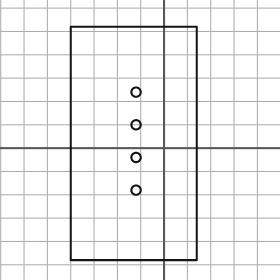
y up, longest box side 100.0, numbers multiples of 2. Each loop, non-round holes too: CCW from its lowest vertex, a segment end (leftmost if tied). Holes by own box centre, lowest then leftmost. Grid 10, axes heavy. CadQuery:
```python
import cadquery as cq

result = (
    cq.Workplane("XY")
    .moveTo(-40.0, -48.0)
    .lineTo(14.0, -48.0)
    .lineTo(14.0, 52.0)
    .lineTo(-40.0, 52.0)
    .close()
    .moveTo(-12.0, -18.0)
    .circle(2.0)
    .moveTo(-12.0, -4.0)
    .circle(2.0)
    .moveTo(-12.0, 10.0)
    .circle(2.0)
    .moveTo(-12.0, 24.0)
    .circle(2.0)
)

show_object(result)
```